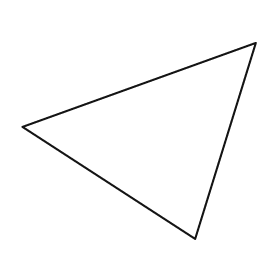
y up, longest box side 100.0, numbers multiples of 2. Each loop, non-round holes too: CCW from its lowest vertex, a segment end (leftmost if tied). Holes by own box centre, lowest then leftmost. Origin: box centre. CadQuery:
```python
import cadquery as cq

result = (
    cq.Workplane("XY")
    .moveTo(24.0, -42.0)
    .lineTo(50.0, 42.0)
    .lineTo(-50.0, 6.0)
    .close()
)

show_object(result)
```